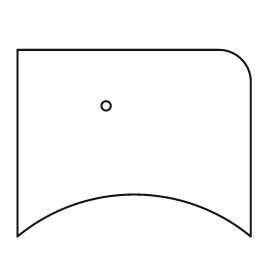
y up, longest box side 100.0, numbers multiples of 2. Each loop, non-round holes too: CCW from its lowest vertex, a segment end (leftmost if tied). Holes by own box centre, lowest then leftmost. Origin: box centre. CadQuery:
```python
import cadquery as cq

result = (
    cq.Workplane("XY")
    .moveTo(-50.0, -40.0)
    .threePointArc((0.0, -22.0), (50.0, -40.0))
    .lineTo(50.0, 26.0)
    .threePointArc((46.0, 36.0), (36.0, 40.0))
    .lineTo(-50.0, 40.0)
    .close()
    .moveTo(-12.0, 16.0)
    .circle(2.0)
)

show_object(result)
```